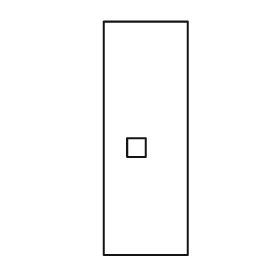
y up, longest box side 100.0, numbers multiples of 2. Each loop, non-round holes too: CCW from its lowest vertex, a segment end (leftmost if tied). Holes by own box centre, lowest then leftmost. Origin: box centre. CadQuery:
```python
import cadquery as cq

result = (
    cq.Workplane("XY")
    .moveTo(-18.0, -50.0)
    .lineTo(18.0, -50.0)
    .lineTo(18.0, 50.0)
    .lineTo(-18.0, 50.0)
    .close()
    .moveTo(-8.0, -8.0)
    .lineTo(0.0, -8.0)
    .lineTo(0.0, 0.0)
    .lineTo(-8.0, 0.0)
    .close()
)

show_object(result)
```